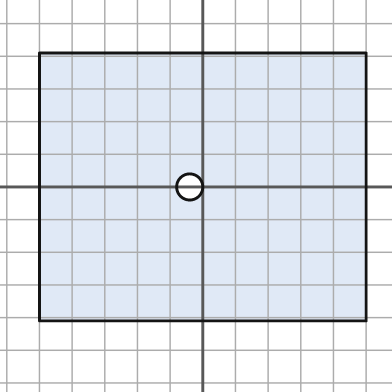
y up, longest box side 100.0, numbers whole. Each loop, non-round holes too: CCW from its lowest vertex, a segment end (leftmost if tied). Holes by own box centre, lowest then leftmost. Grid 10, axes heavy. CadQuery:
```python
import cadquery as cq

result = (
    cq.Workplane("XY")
    .moveTo(-50.0, -41.0)
    .lineTo(50.0, -41.0)
    .lineTo(50.0, 41.0)
    .lineTo(-50.0, 41.0)
    .close()
    .moveTo(-4.0, 0.0)
    .circle(4.0)
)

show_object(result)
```